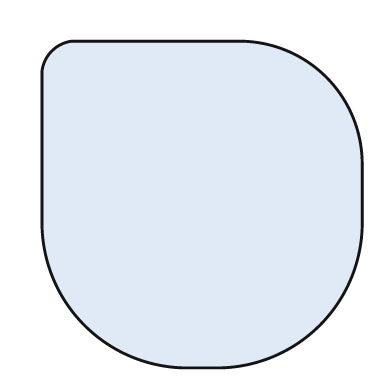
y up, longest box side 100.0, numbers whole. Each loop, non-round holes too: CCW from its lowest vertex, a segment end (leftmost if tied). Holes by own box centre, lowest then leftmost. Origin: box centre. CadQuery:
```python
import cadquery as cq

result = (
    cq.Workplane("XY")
    .moveTo(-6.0, -50.0)
    .lineTo(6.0, -50.0)
    .threePointArc((36.0, -37.0), (49.0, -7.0))
    .lineTo(49.0, 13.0)
    .threePointArc((38.0, 39.0), (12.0, 50.0))
    .lineTo(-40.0, 50.0)
    .threePointArc((-46.0, 47.0), (-49.0, 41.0))
    .lineTo(-49.0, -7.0)
    .threePointArc((-36.0, -37.0), (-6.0, -50.0))
    .close()
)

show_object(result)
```